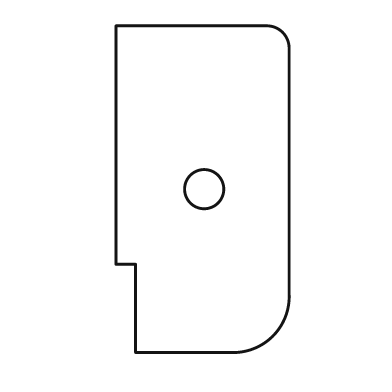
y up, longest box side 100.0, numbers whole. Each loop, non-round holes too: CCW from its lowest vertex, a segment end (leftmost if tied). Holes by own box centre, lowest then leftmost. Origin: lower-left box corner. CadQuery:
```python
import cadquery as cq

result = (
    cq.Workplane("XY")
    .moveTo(6.0, 0.0)
    .lineTo(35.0, 0.0)
    .threePointArc((48.0, 5.0), (53.0, 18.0))
    .lineTo(53.0, 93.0)
    .threePointArc((51.0, 98.0), (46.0, 100.0))
    .lineTo(0.0, 100.0)
    .lineTo(0.0, 27.0)
    .lineTo(6.0, 27.0)
    .close()
    .moveTo(27.0, 50.0)
    .circle(6.0)
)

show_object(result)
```